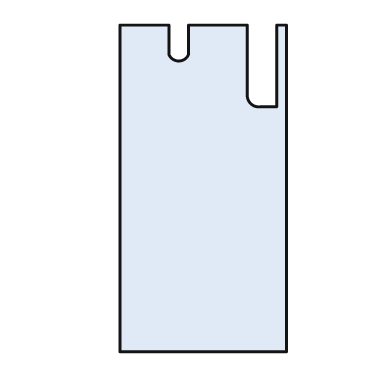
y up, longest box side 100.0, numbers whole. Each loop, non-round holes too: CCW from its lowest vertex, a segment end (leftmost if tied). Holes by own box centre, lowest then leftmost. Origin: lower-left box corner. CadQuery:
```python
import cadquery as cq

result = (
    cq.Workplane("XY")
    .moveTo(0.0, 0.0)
    .lineTo(51.0, 0.0)
    .lineTo(51.0, 100.0)
    .lineTo(48.0, 100.0)
    .lineTo(48.0, 75.0)
    .lineTo(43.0, 75.0)
    .threePointArc((40.0, 76.0), (39.0, 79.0))
    .lineTo(39.0, 100.0)
    .lineTo(21.0, 100.0)
    .lineTo(21.0, 91.0)
    .threePointArc((18.0, 89.0), (15.0, 91.0))
    .lineTo(15.0, 100.0)
    .lineTo(0.0, 100.0)
    .close()
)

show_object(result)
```